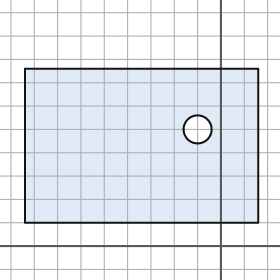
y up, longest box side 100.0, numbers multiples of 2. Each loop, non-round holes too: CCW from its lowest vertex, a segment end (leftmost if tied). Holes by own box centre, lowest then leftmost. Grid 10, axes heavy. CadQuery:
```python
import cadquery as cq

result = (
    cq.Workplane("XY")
    .moveTo(-84.0, 10.0)
    .lineTo(16.0, 10.0)
    .lineTo(16.0, 76.0)
    .lineTo(-84.0, 76.0)
    .close()
    .moveTo(-10.0, 50.0)
    .circle(6.0)
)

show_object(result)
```